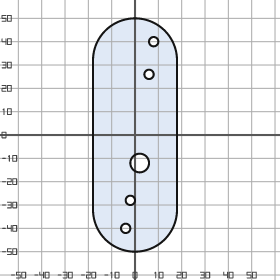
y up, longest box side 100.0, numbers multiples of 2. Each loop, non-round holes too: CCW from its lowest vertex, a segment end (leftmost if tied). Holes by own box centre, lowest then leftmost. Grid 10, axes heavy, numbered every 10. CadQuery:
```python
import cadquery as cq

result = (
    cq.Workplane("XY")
    .moveTo(-18.0, -32.0)
    .threePointArc((0.0, -50.0), (18.0, -32.0))
    .lineTo(18.0, 32.0)
    .threePointArc((0.0, 50.0), (-18.0, 32.0))
    .close()
    .moveTo(-4.0, -40.0)
    .circle(2.0)
    .moveTo(-2.0, -28.0)
    .circle(2.0)
    .moveTo(2.0, -12.0)
    .circle(4.0)
    .moveTo(6.0, 26.0)
    .circle(2.0)
    .moveTo(8.0, 40.0)
    .circle(2.0)
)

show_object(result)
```